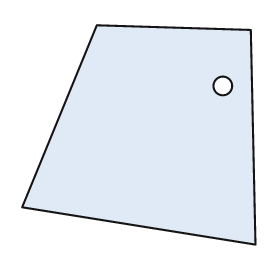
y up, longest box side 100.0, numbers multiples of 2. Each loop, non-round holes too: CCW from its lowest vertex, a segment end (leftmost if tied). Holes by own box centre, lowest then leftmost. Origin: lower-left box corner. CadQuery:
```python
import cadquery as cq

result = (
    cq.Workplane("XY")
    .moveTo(100.0, 0.0)
    .lineTo(98.0, 92.0)
    .lineTo(32.0, 94.0)
    .lineTo(0.0, 16.0)
    .close()
    .moveTo(86.0, 68.0)
    .circle(4.0)
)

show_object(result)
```